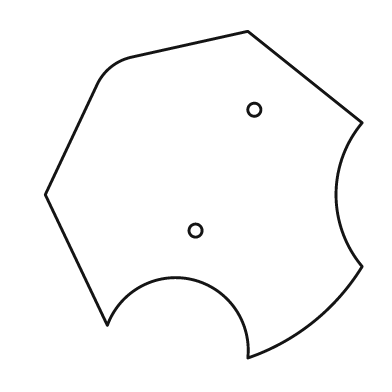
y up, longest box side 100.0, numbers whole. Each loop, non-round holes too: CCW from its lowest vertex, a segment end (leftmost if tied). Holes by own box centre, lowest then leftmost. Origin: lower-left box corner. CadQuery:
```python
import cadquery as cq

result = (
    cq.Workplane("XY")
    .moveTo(62.0, 0.0)
    .threePointArc((82.0, 11.0), (97.0, 28.0))
    .threePointArc((89.0, 50.0), (97.0, 72.0))
    .lineTo(62.0, 100.0)
    .lineTo(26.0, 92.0)
    .threePointArc((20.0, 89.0), (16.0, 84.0))
    .lineTo(0.0, 50.0)
    .lineTo(19.0, 10.0)
    .threePointArc((45.0, 24.0), (62.0, 0.0))
    .close()
    .moveTo(46.0, 39.0)
    .circle(2.0)
    .moveTo(64.0, 76.0)
    .circle(2.0)
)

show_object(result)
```